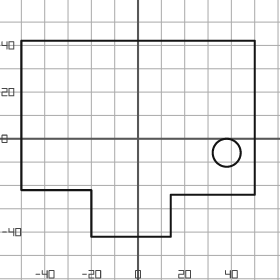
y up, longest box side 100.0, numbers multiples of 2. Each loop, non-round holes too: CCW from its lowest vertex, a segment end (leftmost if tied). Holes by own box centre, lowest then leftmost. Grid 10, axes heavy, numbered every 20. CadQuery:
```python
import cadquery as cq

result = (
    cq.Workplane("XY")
    .moveTo(-20.0, -42.0)
    .lineTo(14.0, -42.0)
    .lineTo(14.0, -24.0)
    .lineTo(50.0, -24.0)
    .lineTo(50.0, 42.0)
    .lineTo(-50.0, 42.0)
    .lineTo(-50.0, -22.0)
    .lineTo(-20.0, -22.0)
    .close()
    .moveTo(38.0, -6.0)
    .circle(6.0)
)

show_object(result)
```